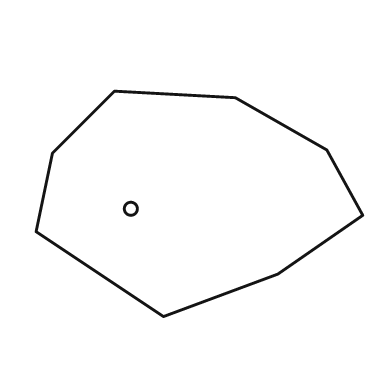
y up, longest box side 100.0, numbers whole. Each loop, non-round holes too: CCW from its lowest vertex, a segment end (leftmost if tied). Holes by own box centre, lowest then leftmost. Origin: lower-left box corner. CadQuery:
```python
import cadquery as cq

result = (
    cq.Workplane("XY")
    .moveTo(39.0, 0.0)
    .lineTo(74.0, 13.0)
    .lineTo(100.0, 31.0)
    .lineTo(89.0, 51.0)
    .lineTo(61.0, 67.0)
    .lineTo(24.0, 69.0)
    .lineTo(5.0, 50.0)
    .lineTo(0.0, 26.0)
    .close()
    .moveTo(29.0, 33.0)
    .circle(2.0)
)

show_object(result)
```